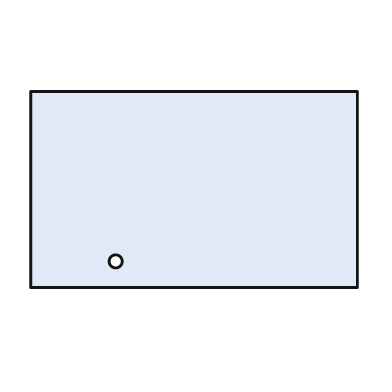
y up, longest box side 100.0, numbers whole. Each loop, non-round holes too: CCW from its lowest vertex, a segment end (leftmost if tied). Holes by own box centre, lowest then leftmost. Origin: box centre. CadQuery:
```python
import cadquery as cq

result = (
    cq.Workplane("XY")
    .moveTo(-50.0, -30.0)
    .lineTo(50.0, -30.0)
    .lineTo(50.0, 30.0)
    .lineTo(-50.0, 30.0)
    .close()
    .moveTo(-24.0, -22.0)
    .circle(2.0)
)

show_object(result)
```